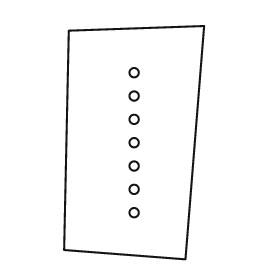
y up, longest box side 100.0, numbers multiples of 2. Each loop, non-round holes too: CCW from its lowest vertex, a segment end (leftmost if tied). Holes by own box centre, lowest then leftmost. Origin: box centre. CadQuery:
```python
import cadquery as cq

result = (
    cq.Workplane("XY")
    .moveTo(22.0, -50.0)
    .lineTo(30.0, 50.0)
    .lineTo(-28.0, 48.0)
    .lineTo(-30.0, -46.0)
    .close()
    .moveTo(0.0, -30.0)
    .circle(2.0)
    .moveTo(0.0, -20.0)
    .circle(2.0)
    .moveTo(0.0, -10.0)
    .circle(2.0)
    .moveTo(0.0, 0.0)
    .circle(2.0)
    .moveTo(0.0, 10.0)
    .circle(2.0)
    .moveTo(0.0, 20.0)
    .circle(2.0)
    .moveTo(0.0, 30.0)
    .circle(2.0)
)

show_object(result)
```